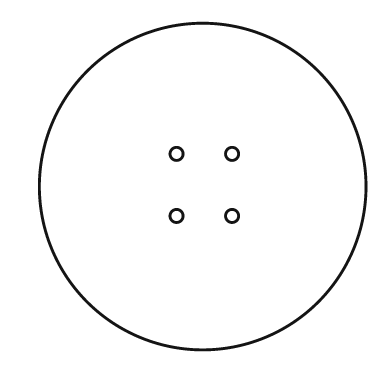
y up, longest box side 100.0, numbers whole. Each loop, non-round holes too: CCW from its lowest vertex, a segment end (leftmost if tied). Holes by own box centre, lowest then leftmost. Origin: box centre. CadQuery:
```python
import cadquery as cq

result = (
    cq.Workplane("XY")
    .moveTo(0.0, 0.0)
    .circle(50.0)
    .moveTo(-8.0, -9.0)
    .circle(2.0)
    .moveTo(9.0, -9.0)
    .circle(2.0)
    .moveTo(-8.0, 10.0)
    .circle(2.0)
    .moveTo(9.0, 10.0)
    .circle(2.0)
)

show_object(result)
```